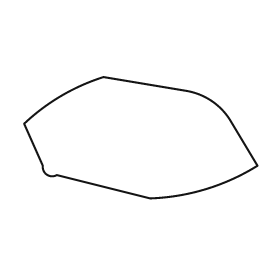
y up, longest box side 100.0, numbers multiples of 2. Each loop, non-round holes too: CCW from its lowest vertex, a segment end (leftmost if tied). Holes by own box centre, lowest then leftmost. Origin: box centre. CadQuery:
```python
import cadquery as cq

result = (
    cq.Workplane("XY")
    .moveTo(4.0, -26.0)
    .threePointArc((28.0, -22.0), (50.0, -12.0))
    .lineTo(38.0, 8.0)
    .threePointArc((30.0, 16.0), (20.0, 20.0))
    .lineTo(-16.0, 26.0)
    .threePointArc((-34.0, 18.0), (-50.0, 6.0))
    .lineTo(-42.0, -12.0)
    .threePointArc((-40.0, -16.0), (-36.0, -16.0))
    .close()
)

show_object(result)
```